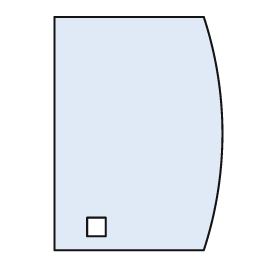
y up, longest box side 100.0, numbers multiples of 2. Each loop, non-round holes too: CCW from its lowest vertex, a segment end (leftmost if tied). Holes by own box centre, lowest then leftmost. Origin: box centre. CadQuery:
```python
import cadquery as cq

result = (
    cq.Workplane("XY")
    .moveTo(-36.0, -50.0)
    .lineTo(28.0, -50.0)
    .threePointArc((36.0, 0.0), (28.0, 50.0))
    .lineTo(-36.0, 50.0)
    .close()
    .moveTo(-22.0, -44.0)
    .lineTo(-14.0, -44.0)
    .lineTo(-14.0, -36.0)
    .lineTo(-22.0, -36.0)
    .close()
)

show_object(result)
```